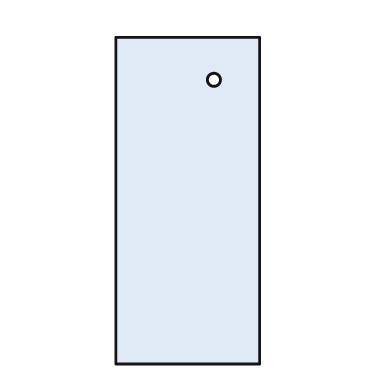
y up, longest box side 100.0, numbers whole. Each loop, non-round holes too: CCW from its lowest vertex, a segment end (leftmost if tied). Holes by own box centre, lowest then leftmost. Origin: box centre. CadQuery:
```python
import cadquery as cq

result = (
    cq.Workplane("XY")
    .moveTo(-22.0, -50.0)
    .lineTo(22.0, -50.0)
    .lineTo(22.0, 50.0)
    .lineTo(-22.0, 50.0)
    .close()
    .moveTo(8.0, 37.0)
    .circle(2.0)
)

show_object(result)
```